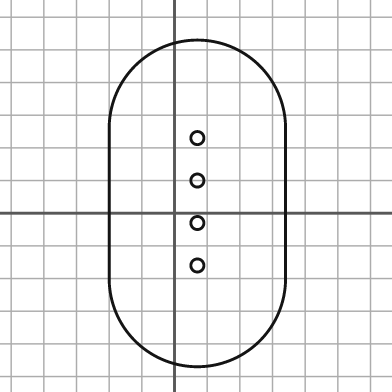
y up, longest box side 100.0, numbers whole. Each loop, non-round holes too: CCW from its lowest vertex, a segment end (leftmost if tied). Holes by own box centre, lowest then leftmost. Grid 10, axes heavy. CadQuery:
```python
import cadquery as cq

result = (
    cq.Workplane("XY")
    .moveTo(-20.0, -20.0)
    .threePointArc((7.0, -47.0), (34.0, -20.0))
    .lineTo(34.0, 26.0)
    .threePointArc((7.0, 53.0), (-20.0, 26.0))
    .close()
    .moveTo(7.0, -16.0)
    .circle(2.0)
    .moveTo(7.0, -3.0)
    .circle(2.0)
    .moveTo(7.0, 10.0)
    .circle(2.0)
    .moveTo(7.0, 23.0)
    .circle(2.0)
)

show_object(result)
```